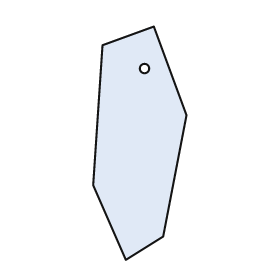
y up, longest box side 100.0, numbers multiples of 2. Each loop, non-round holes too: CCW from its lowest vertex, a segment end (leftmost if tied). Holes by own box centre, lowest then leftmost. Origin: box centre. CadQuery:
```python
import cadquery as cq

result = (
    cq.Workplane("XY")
    .moveTo(-6.0, -50.0)
    .lineTo(10.0, -40.0)
    .lineTo(20.0, 12.0)
    .lineTo(6.0, 50.0)
    .lineTo(-16.0, 42.0)
    .lineTo(-20.0, -18.0)
    .close()
    .moveTo(2.0, 32.0)
    .circle(2.0)
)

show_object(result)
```